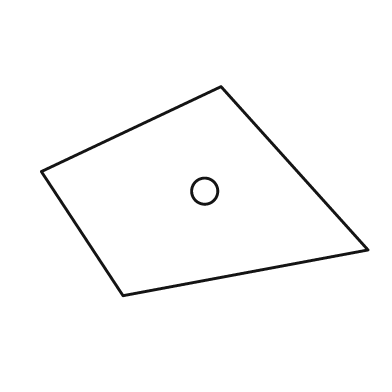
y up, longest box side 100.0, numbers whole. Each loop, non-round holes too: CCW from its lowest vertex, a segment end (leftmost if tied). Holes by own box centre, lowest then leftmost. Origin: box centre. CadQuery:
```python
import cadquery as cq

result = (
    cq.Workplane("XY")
    .moveTo(-25.0, -32.0)
    .lineTo(50.0, -18.0)
    .lineTo(5.0, 32.0)
    .lineTo(-50.0, 6.0)
    .close()
    .moveTo(0.0, 0.0)
    .circle(4.0)
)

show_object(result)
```